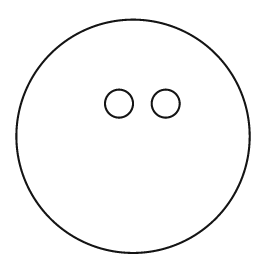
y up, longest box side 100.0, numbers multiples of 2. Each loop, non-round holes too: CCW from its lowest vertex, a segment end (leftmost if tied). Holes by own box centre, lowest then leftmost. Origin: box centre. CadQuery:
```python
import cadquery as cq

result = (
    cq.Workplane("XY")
    .moveTo(0.0, 0.0)
    .circle(50.0)
    .moveTo(-6.0, 14.0)
    .circle(6.0)
    .moveTo(14.0, 14.0)
    .circle(6.0)
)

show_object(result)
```